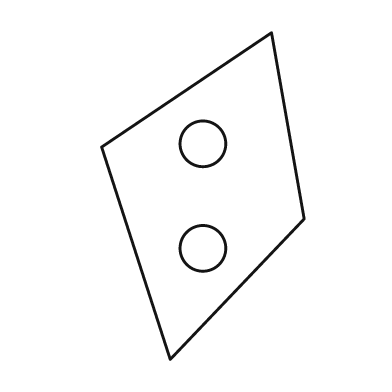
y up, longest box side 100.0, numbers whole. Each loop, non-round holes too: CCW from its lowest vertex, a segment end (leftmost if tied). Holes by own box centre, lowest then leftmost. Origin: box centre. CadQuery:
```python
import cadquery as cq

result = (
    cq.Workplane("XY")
    .moveTo(-10.0, -50.0)
    .lineTo(31.0, -7.0)
    .lineTo(21.0, 50.0)
    .lineTo(-31.0, 15.0)
    .close()
    .moveTo(0.0, -16.0)
    .circle(7.0)
    .moveTo(0.0, 16.0)
    .circle(7.0)
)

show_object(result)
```